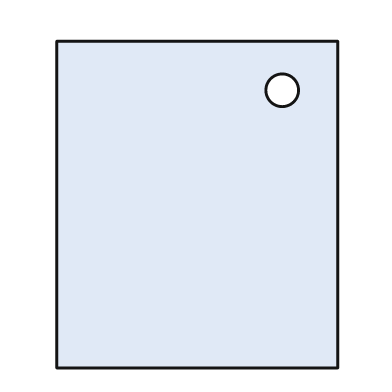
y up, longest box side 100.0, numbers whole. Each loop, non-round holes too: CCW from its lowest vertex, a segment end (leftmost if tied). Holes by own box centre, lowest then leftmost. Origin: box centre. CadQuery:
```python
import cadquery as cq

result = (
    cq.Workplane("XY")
    .moveTo(-43.0, -50.0)
    .lineTo(43.0, -50.0)
    .lineTo(43.0, 50.0)
    .lineTo(-43.0, 50.0)
    .close()
    .moveTo(26.0, 35.0)
    .circle(5.0)
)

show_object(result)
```